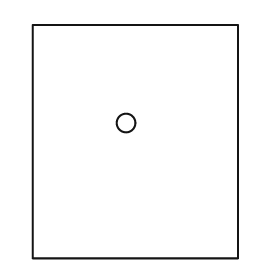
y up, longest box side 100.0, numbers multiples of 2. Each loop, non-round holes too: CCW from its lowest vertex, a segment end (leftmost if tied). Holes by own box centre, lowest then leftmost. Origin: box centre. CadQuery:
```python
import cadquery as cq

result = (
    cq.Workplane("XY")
    .moveTo(-44.0, -50.0)
    .lineTo(44.0, -50.0)
    .lineTo(44.0, 50.0)
    .lineTo(-44.0, 50.0)
    .close()
    .moveTo(-4.0, 8.0)
    .circle(4.0)
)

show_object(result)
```